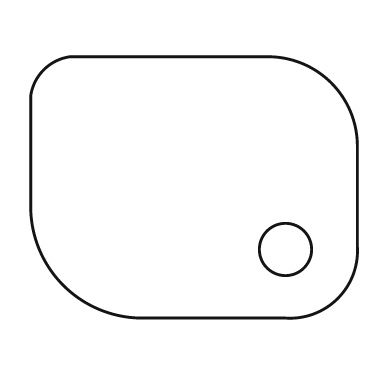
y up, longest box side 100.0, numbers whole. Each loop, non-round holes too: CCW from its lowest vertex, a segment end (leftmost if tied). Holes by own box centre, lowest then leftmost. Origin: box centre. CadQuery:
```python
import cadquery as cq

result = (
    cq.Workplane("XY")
    .moveTo(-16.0, -40.0)
    .lineTo(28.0, -40.0)
    .threePointArc((44.0, -34.0), (50.0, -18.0))
    .lineTo(50.0, 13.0)
    .threePointArc((42.0, 32.0), (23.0, 40.0))
    .lineTo(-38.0, 40.0)
    .threePointArc((-46.0, 36.0), (-50.0, 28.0))
    .lineTo(-50.0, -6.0)
    .threePointArc((-40.0, -30.0), (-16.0, -40.0))
    .close()
    .moveTo(28.0, -19.0)
    .circle(8.0)
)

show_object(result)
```